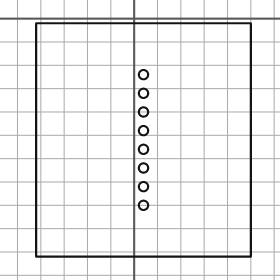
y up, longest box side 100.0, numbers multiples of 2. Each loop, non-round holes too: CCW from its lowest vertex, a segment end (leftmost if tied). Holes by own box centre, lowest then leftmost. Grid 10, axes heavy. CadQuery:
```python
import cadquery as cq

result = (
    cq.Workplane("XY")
    .moveTo(-42.0, -102.0)
    .lineTo(50.0, -102.0)
    .lineTo(50.0, -2.0)
    .lineTo(-42.0, -2.0)
    .close()
    .moveTo(4.0, -80.0)
    .circle(2.0)
    .moveTo(4.0, -72.0)
    .circle(2.0)
    .moveTo(4.0, -64.0)
    .circle(2.0)
    .moveTo(4.0, -56.0)
    .circle(2.0)
    .moveTo(4.0, -48.0)
    .circle(2.0)
    .moveTo(4.0, -40.0)
    .circle(2.0)
    .moveTo(4.0, -32.0)
    .circle(2.0)
    .moveTo(4.0, -24.0)
    .circle(2.0)
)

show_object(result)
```